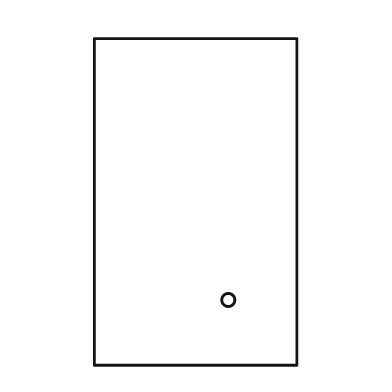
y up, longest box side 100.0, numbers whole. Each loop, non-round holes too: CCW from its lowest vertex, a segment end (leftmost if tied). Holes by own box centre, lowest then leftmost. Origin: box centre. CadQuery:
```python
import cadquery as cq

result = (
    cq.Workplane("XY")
    .moveTo(-31.0, -50.0)
    .lineTo(31.0, -50.0)
    .lineTo(31.0, 50.0)
    .lineTo(-31.0, 50.0)
    .close()
    .moveTo(10.0, -30.0)
    .circle(2.0)
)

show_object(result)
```